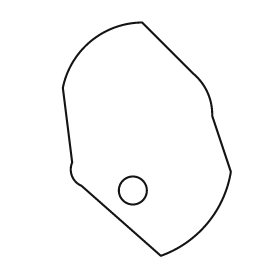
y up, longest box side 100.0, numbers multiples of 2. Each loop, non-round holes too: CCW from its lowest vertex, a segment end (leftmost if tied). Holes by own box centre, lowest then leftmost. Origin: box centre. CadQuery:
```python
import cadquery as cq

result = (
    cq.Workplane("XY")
    .moveTo(6.0, -50.0)
    .threePointArc((26.0, -36.0), (36.0, -14.0))
    .lineTo(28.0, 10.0)
    .threePointArc((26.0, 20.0), (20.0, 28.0))
    .lineTo(-2.0, 50.0)
    .threePointArc((-24.0, 42.0), (-36.0, 22.0))
    .lineTo(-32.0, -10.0)
    .threePointArc((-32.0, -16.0), (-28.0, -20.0))
    .close()
    .moveTo(-6.0, -22.0)
    .circle(6.0)
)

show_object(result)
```